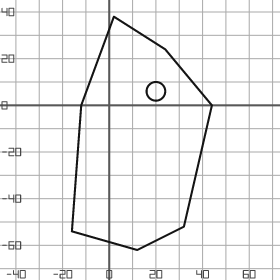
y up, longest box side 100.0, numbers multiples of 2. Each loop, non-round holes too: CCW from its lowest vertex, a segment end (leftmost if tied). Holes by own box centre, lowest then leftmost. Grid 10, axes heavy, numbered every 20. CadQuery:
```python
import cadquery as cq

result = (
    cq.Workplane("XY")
    .moveTo(12.0, -62.0)
    .lineTo(32.0, -52.0)
    .lineTo(44.0, 0.0)
    .lineTo(24.0, 24.0)
    .lineTo(2.0, 38.0)
    .lineTo(-12.0, 0.0)
    .lineTo(-16.0, -54.0)
    .close()
    .moveTo(20.0, 6.0)
    .circle(4.0)
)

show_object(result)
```